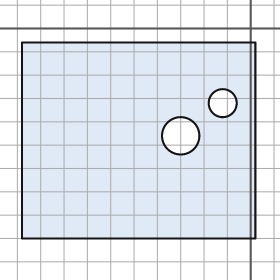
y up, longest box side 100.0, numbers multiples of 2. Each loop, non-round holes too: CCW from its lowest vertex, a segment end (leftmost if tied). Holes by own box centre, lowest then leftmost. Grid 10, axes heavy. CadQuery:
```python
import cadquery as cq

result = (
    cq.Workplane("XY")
    .moveTo(-98.0, -90.0)
    .lineTo(2.0, -90.0)
    .lineTo(2.0, -6.0)
    .lineTo(-98.0, -6.0)
    .close()
    .moveTo(-30.0, -46.0)
    .circle(8.0)
    .moveTo(-12.0, -32.0)
    .circle(6.0)
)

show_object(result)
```